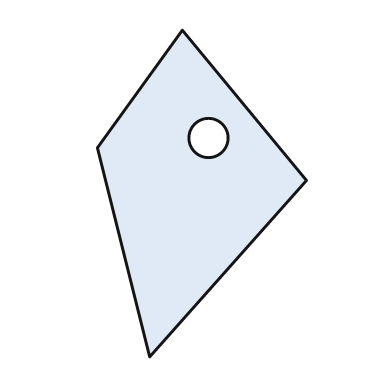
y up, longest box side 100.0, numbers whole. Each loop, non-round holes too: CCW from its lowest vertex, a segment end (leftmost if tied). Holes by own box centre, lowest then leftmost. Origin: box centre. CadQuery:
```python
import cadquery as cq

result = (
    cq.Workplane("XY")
    .moveTo(-16.0, -50.0)
    .lineTo(32.0, 4.0)
    .lineTo(-6.0, 50.0)
    .lineTo(-32.0, 14.0)
    .close()
    .moveTo(2.0, 17.0)
    .circle(6.0)
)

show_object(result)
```